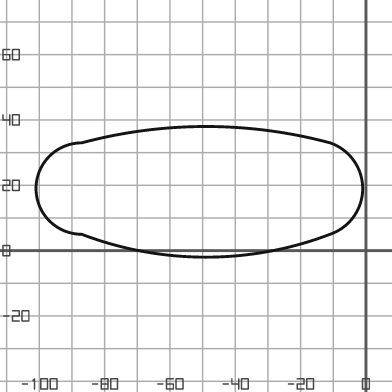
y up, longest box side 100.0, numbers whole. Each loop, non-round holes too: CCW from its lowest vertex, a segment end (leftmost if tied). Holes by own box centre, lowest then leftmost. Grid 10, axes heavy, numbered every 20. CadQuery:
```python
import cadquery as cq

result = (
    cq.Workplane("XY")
    .moveTo(-87.0, 5.0)
    .threePointArc((-49.0, -2.0), (-11.0, 5.0))
    .threePointArc((-1.0, 19.0), (-11.0, 33.0))
    .threePointArc((-49.0, 38.0), (-87.0, 33.0))
    .threePointArc((-101.0, 19.0), (-87.0, 5.0))
    .close()
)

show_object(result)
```